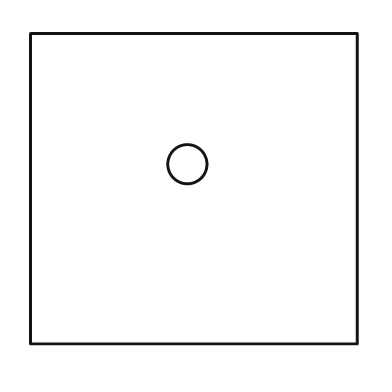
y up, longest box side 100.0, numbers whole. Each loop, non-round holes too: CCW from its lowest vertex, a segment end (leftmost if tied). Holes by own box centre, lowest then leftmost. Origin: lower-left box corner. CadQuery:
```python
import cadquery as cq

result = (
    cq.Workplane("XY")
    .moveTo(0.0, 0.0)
    .lineTo(100.0, 0.0)
    .lineTo(100.0, 95.0)
    .lineTo(0.0, 95.0)
    .close()
    .moveTo(48.0, 55.0)
    .circle(6.0)
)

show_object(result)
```